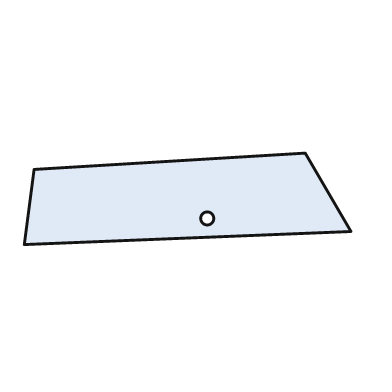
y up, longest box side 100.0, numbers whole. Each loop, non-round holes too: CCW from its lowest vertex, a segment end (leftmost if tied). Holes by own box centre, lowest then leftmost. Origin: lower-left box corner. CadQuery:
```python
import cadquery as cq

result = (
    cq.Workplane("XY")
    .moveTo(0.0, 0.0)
    .lineTo(100.0, 4.0)
    .lineTo(86.0, 28.0)
    .lineTo(3.0, 23.0)
    .close()
    .moveTo(56.0, 8.0)
    .circle(2.0)
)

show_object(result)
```